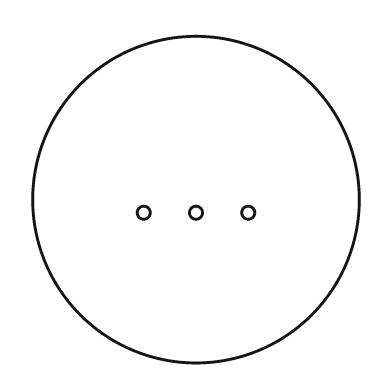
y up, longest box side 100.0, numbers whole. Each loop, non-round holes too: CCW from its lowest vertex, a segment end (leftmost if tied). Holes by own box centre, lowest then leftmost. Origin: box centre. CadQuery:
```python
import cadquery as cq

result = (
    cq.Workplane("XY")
    .moveTo(0.0, 0.0)
    .circle(50.0)
    .moveTo(-16.0, -4.0)
    .circle(2.0)
    .moveTo(0.0, -4.0)
    .circle(2.0)
    .moveTo(16.0, -4.0)
    .circle(2.0)
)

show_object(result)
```